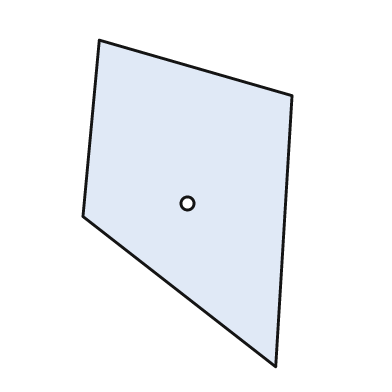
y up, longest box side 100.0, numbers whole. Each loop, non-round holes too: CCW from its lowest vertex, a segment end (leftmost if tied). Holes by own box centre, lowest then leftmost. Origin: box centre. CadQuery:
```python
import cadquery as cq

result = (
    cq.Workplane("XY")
    .moveTo(27.0, -50.0)
    .lineTo(32.0, 33.0)
    .lineTo(-27.0, 50.0)
    .lineTo(-32.0, -4.0)
    .close()
    .moveTo(0.0, 0.0)
    .circle(2.0)
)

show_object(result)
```